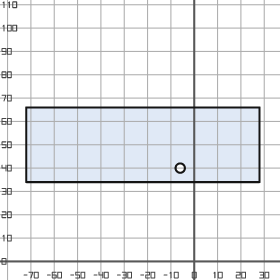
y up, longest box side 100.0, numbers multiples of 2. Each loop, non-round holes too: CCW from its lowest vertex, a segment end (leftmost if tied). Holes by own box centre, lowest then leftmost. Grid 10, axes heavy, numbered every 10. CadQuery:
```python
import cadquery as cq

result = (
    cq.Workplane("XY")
    .moveTo(-72.0, 34.0)
    .lineTo(28.0, 34.0)
    .lineTo(28.0, 66.0)
    .lineTo(-72.0, 66.0)
    .close()
    .moveTo(-6.0, 40.0)
    .circle(2.0)
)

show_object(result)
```